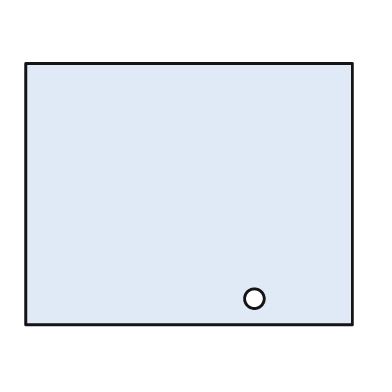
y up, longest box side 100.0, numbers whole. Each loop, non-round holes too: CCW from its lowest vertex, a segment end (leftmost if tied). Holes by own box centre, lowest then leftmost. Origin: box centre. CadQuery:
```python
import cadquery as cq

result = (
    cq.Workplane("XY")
    .moveTo(-50.0, -40.0)
    .lineTo(50.0, -40.0)
    .lineTo(50.0, 40.0)
    .lineTo(-50.0, 40.0)
    .close()
    .moveTo(20.0, -32.0)
    .circle(3.0)
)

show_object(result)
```